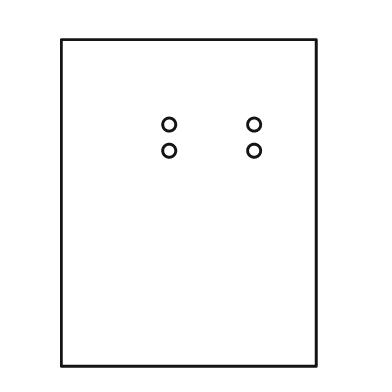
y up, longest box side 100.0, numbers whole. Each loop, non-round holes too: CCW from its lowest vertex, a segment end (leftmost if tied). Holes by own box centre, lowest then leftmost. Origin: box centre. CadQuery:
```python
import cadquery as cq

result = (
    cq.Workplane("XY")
    .moveTo(-39.0, -50.0)
    .lineTo(39.0, -50.0)
    .lineTo(39.0, 50.0)
    .lineTo(-39.0, 50.0)
    .close()
    .moveTo(-6.0, 16.0)
    .circle(2.0)
    .moveTo(20.0, 16.0)
    .circle(2.0)
    .moveTo(-6.0, 24.0)
    .circle(2.0)
    .moveTo(20.0, 24.0)
    .circle(2.0)
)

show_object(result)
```